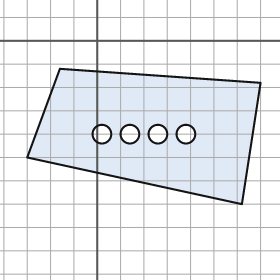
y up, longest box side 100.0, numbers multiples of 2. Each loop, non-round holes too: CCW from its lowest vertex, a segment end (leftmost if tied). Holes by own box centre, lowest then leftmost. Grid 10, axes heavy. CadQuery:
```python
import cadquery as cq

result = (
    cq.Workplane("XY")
    .moveTo(62.0, -70.0)
    .lineTo(70.0, -18.0)
    .lineTo(-16.0, -12.0)
    .lineTo(-30.0, -50.0)
    .close()
    .moveTo(2.0, -40.0)
    .circle(4.0)
    .moveTo(14.0, -40.0)
    .circle(4.0)
    .moveTo(26.0, -40.0)
    .circle(4.0)
    .moveTo(38.0, -40.0)
    .circle(4.0)
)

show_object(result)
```